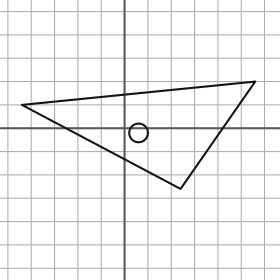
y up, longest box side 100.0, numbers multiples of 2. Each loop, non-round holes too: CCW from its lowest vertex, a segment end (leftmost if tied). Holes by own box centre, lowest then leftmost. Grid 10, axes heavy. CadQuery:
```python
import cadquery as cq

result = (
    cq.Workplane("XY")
    .moveTo(24.0, -26.0)
    .lineTo(56.0, 20.0)
    .lineTo(-44.0, 10.0)
    .close()
    .moveTo(6.0, -2.0)
    .circle(4.0)
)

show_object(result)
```